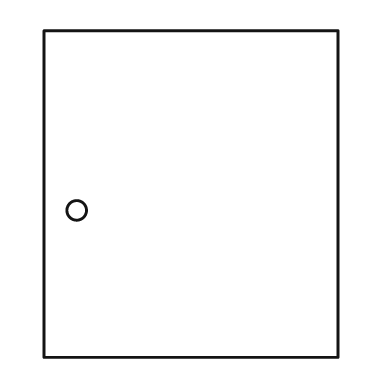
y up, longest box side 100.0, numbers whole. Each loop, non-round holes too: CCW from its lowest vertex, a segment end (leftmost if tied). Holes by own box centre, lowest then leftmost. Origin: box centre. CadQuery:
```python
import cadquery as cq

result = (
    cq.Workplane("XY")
    .moveTo(-45.0, -50.0)
    .lineTo(45.0, -50.0)
    .lineTo(45.0, 50.0)
    .lineTo(-45.0, 50.0)
    .close()
    .moveTo(-35.0, -5.0)
    .circle(3.0)
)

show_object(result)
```